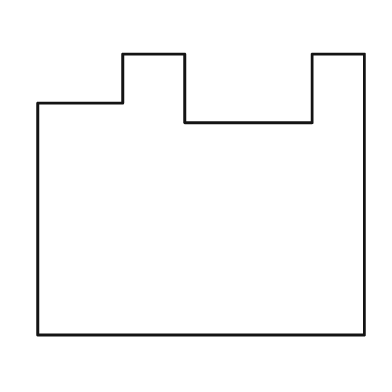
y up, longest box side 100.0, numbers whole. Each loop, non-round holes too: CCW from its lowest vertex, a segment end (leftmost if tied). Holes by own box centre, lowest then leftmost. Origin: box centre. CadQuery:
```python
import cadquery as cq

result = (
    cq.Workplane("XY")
    .moveTo(-50.0, -43.0)
    .lineTo(50.0, -43.0)
    .lineTo(50.0, 43.0)
    .lineTo(34.0, 43.0)
    .lineTo(34.0, 22.0)
    .lineTo(-5.0, 22.0)
    .lineTo(-5.0, 43.0)
    .lineTo(-24.0, 43.0)
    .lineTo(-24.0, 28.0)
    .lineTo(-50.0, 28.0)
    .close()
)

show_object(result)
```